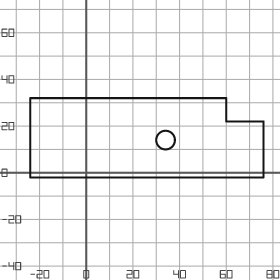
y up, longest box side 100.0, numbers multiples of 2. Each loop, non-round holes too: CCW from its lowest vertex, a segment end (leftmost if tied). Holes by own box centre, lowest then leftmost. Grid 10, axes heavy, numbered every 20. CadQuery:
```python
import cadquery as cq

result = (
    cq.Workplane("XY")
    .moveTo(-24.0, -2.0)
    .lineTo(76.0, -2.0)
    .lineTo(76.0, 22.0)
    .lineTo(60.0, 22.0)
    .lineTo(60.0, 32.0)
    .lineTo(-24.0, 32.0)
    .close()
    .moveTo(34.0, 14.0)
    .circle(4.0)
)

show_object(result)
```